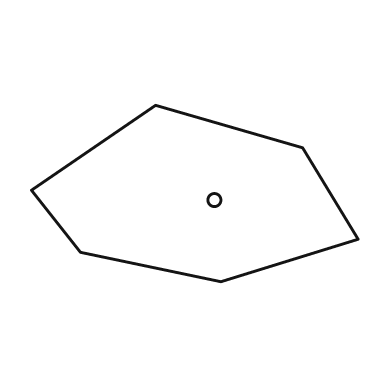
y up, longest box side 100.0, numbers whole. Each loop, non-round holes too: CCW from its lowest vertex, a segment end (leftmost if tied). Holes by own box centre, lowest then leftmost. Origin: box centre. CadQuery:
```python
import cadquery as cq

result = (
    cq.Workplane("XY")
    .moveTo(8.0, -27.0)
    .lineTo(50.0, -14.0)
    .lineTo(33.0, 14.0)
    .lineTo(-12.0, 27.0)
    .lineTo(-50.0, 1.0)
    .lineTo(-35.0, -18.0)
    .close()
    .moveTo(6.0, -2.0)
    .circle(2.0)
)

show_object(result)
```